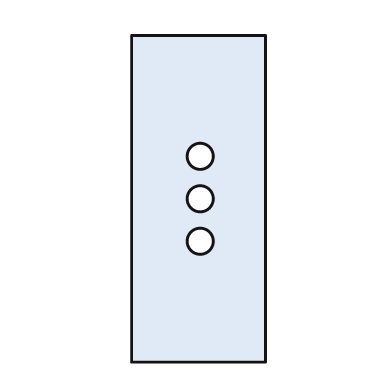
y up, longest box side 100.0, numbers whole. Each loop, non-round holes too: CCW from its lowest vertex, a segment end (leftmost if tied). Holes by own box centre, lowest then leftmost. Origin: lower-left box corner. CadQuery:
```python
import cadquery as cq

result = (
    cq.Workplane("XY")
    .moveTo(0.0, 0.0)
    .lineTo(41.0, 0.0)
    .lineTo(41.0, 100.0)
    .lineTo(0.0, 100.0)
    .close()
    .moveTo(21.0, 37.0)
    .circle(4.0)
    .moveTo(21.0, 50.0)
    .circle(4.0)
    .moveTo(21.0, 63.0)
    .circle(4.0)
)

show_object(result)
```